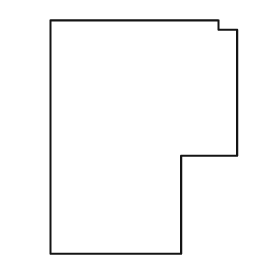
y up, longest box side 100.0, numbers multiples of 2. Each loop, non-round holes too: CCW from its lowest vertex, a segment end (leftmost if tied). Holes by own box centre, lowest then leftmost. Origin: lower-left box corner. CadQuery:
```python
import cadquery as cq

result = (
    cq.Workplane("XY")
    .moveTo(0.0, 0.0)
    .lineTo(56.0, 0.0)
    .lineTo(56.0, 42.0)
    .lineTo(80.0, 42.0)
    .lineTo(80.0, 96.0)
    .lineTo(72.0, 96.0)
    .lineTo(72.0, 100.0)
    .lineTo(0.0, 100.0)
    .close()
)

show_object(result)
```